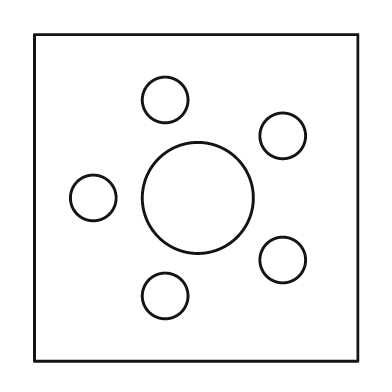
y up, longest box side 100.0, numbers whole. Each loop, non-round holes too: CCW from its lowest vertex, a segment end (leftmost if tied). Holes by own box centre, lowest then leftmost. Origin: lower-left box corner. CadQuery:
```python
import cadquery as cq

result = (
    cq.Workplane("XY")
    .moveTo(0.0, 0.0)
    .lineTo(99.0, 0.0)
    .lineTo(99.0, 100.0)
    .lineTo(0.0, 100.0)
    .close()
    .moveTo(40.0, 20.0)
    .circle(7.0)
    .moveTo(76.0, 31.0)
    .circle(7.0)
    .moveTo(18.0, 50.0)
    .circle(7.0)
    .moveTo(50.0, 50.0)
    .circle(17.0)
    .moveTo(76.0, 69.0)
    .circle(7.0)
    .moveTo(40.0, 80.0)
    .circle(7.0)
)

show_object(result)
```